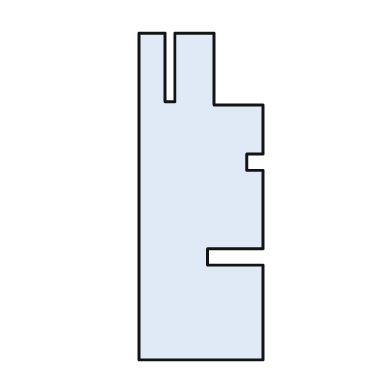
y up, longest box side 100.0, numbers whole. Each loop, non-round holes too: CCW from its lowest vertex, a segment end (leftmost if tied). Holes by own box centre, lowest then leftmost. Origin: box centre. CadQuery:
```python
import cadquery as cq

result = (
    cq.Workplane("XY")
    .moveTo(-19.0, -50.0)
    .lineTo(19.0, -50.0)
    .lineTo(19.0, -21.0)
    .lineTo(2.0, -21.0)
    .lineTo(2.0, -16.0)
    .lineTo(19.0, -16.0)
    .lineTo(19.0, 8.0)
    .lineTo(14.0, 8.0)
    .lineTo(14.0, 13.0)
    .lineTo(19.0, 13.0)
    .lineTo(19.0, 28.0)
    .lineTo(4.0, 28.0)
    .lineTo(4.0, 50.0)
    .lineTo(-8.0, 50.0)
    .lineTo(-8.0, 29.0)
    .lineTo(-11.0, 29.0)
    .lineTo(-11.0, 50.0)
    .lineTo(-19.0, 50.0)
    .close()
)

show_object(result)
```